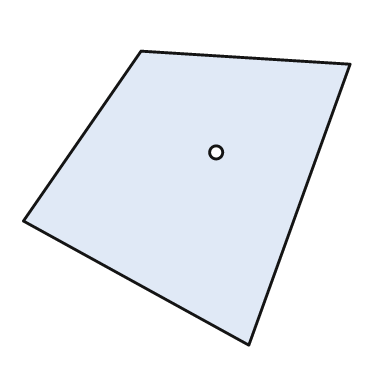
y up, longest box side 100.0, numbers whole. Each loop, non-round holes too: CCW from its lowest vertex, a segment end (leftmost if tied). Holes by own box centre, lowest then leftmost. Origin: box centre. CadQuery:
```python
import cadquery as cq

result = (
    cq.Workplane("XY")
    .moveTo(19.0, -45.0)
    .lineTo(50.0, 41.0)
    .lineTo(-14.0, 45.0)
    .lineTo(-50.0, -7.0)
    .close()
    .moveTo(9.0, 14.0)
    .circle(2.0)
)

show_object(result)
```